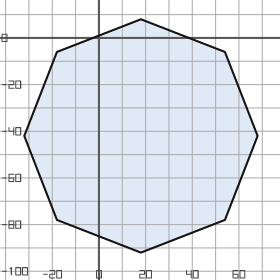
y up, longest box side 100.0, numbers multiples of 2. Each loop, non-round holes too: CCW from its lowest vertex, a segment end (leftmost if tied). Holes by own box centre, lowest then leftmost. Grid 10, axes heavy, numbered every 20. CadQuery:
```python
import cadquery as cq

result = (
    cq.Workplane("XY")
    .moveTo(18.0, -92.0)
    .lineTo(54.0, -78.0)
    .lineTo(68.0, -42.0)
    .lineTo(54.0, -6.0)
    .lineTo(18.0, 8.0)
    .lineTo(-18.0, -6.0)
    .lineTo(-32.0, -42.0)
    .lineTo(-18.0, -78.0)
    .close()
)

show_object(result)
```